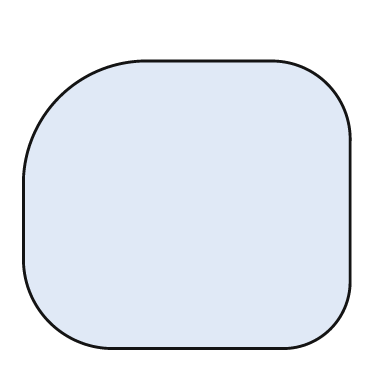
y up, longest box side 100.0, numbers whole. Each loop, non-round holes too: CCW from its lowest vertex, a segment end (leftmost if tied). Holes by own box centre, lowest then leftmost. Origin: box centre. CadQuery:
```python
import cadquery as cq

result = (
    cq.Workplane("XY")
    .moveTo(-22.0, -44.0)
    .lineTo(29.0, -44.0)
    .threePointArc((44.0, -38.0), (50.0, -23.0))
    .lineTo(50.0, 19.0)
    .threePointArc((43.0, 37.0), (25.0, 44.0))
    .lineTo(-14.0, 44.0)
    .threePointArc((-39.0, 33.0), (-50.0, 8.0))
    .lineTo(-50.0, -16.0)
    .threePointArc((-42.0, -36.0), (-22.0, -44.0))
    .close()
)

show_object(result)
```